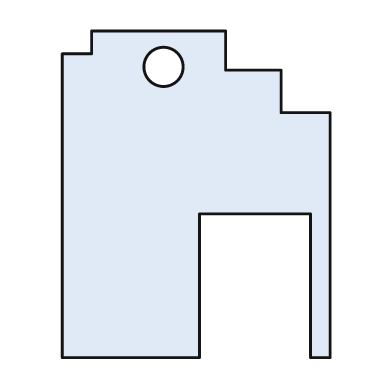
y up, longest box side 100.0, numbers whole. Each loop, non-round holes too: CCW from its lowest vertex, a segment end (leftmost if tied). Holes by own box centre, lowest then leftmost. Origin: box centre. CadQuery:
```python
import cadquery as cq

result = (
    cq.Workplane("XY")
    .moveTo(-41.0, -50.0)
    .lineTo(1.0, -50.0)
    .lineTo(1.0, -6.0)
    .lineTo(35.0, -6.0)
    .lineTo(35.0, -50.0)
    .lineTo(41.0, -50.0)
    .lineTo(41.0, 25.0)
    .lineTo(26.0, 25.0)
    .lineTo(26.0, 38.0)
    .lineTo(9.0, 38.0)
    .lineTo(9.0, 50.0)
    .lineTo(-32.0, 50.0)
    .lineTo(-32.0, 43.0)
    .lineTo(-41.0, 43.0)
    .close()
    .moveTo(-10.0, 39.0)
    .circle(6.0)
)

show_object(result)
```